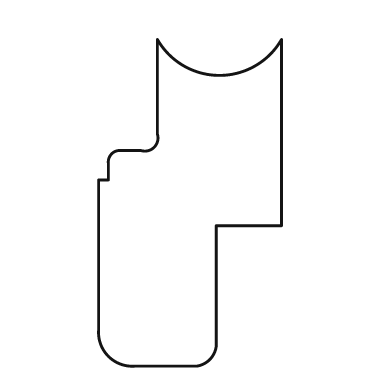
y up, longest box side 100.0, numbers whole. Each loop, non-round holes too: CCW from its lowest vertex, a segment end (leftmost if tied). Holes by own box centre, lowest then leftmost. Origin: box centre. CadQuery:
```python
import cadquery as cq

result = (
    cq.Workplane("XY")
    .moveTo(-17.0, -50.0)
    .lineTo(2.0, -50.0)
    .threePointArc((6.0, -48.0), (8.0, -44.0))
    .lineTo(8.0, -7.0)
    .lineTo(28.0, -7.0)
    .lineTo(28.0, 50.0)
    .threePointArc((9.0, 39.0), (-10.0, 50.0))
    .lineTo(-10.0, 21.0)
    .threePointArc((-11.0, 17.0), (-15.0, 16.0))
    .lineTo(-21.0, 16.0)
    .threePointArc((-24.0, 15.0), (-25.0, 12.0))
    .lineTo(-25.0, 7.0)
    .lineTo(-28.0, 7.0)
    .lineTo(-28.0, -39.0)
    .threePointArc((-25.0, -47.0), (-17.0, -50.0))
    .close()
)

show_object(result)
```